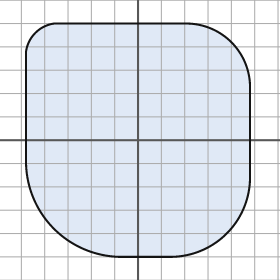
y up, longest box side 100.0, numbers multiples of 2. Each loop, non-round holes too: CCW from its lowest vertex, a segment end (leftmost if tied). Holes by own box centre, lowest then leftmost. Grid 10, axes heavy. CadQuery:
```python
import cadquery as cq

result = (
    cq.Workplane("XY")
    .moveTo(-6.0, -50.0)
    .lineTo(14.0, -50.0)
    .threePointArc((38.0, -40.0), (48.0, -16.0))
    .lineTo(48.0, 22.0)
    .threePointArc((40.0, 42.0), (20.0, 50.0))
    .lineTo(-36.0, 50.0)
    .threePointArc((-44.0, 46.0), (-48.0, 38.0))
    .lineTo(-48.0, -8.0)
    .threePointArc((-36.0, -38.0), (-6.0, -50.0))
    .close()
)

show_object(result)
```